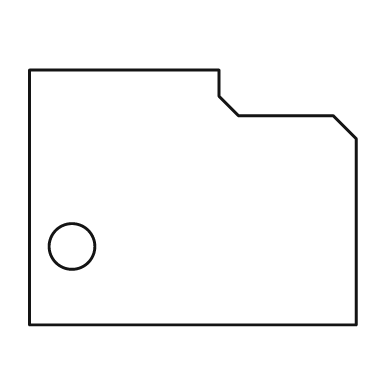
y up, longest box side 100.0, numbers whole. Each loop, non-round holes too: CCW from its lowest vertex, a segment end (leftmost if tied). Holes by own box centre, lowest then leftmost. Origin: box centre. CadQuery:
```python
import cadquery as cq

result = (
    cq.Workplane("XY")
    .moveTo(-50.0, -39.0)
    .lineTo(50.0, -39.0)
    .lineTo(50.0, 18.0)
    .lineTo(43.0, 25.0)
    .lineTo(14.0, 25.0)
    .lineTo(8.0, 31.0)
    .lineTo(8.0, 39.0)
    .lineTo(-50.0, 39.0)
    .close()
    .moveTo(-37.0, -15.0)
    .circle(7.0)
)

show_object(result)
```